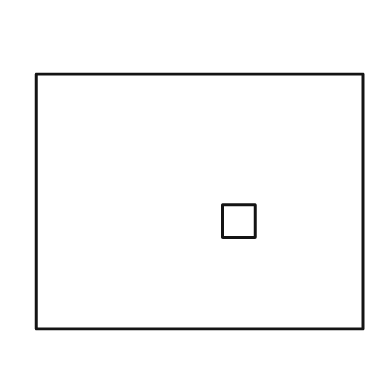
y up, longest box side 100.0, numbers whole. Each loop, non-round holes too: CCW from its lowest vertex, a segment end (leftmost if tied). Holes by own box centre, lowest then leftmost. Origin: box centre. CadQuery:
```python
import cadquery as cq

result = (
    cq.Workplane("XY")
    .moveTo(-50.0, -39.0)
    .lineTo(50.0, -39.0)
    .lineTo(50.0, 39.0)
    .lineTo(-50.0, 39.0)
    .close()
    .moveTo(7.0, -11.0)
    .lineTo(17.0, -11.0)
    .lineTo(17.0, -1.0)
    .lineTo(7.0, -1.0)
    .close()
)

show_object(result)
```